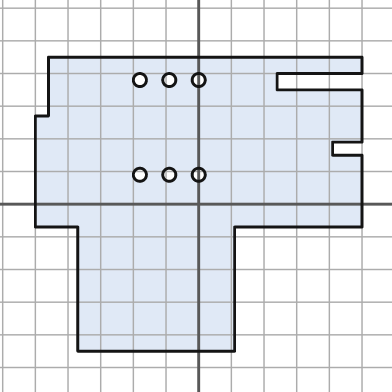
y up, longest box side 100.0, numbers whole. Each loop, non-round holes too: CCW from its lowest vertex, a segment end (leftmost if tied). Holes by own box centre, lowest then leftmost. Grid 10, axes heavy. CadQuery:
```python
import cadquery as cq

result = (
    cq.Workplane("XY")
    .moveTo(-37.0, -45.0)
    .lineTo(11.0, -45.0)
    .lineTo(11.0, -7.0)
    .lineTo(50.0, -7.0)
    .lineTo(50.0, 15.0)
    .lineTo(41.0, 15.0)
    .lineTo(41.0, 19.0)
    .lineTo(50.0, 19.0)
    .lineTo(50.0, 35.0)
    .lineTo(24.0, 35.0)
    .lineTo(24.0, 40.0)
    .lineTo(50.0, 40.0)
    .lineTo(50.0, 45.0)
    .lineTo(-46.0, 45.0)
    .lineTo(-46.0, 27.0)
    .lineTo(-50.0, 27.0)
    .lineTo(-50.0, -7.0)
    .lineTo(-37.0, -7.0)
    .close()
    .moveTo(-18.0, 9.0)
    .circle(2.0)
    .moveTo(-9.0, 9.0)
    .circle(2.0)
    .moveTo(0.0, 9.0)
    .circle(2.0)
    .moveTo(-18.0, 38.0)
    .circle(2.0)
    .moveTo(-9.0, 38.0)
    .circle(2.0)
    .moveTo(0.0, 38.0)
    .circle(2.0)
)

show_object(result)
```